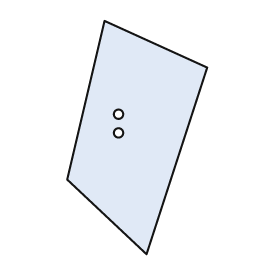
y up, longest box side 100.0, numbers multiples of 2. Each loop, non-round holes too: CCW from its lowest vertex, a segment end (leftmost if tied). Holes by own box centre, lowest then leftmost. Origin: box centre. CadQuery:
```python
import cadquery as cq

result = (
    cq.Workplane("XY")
    .moveTo(4.0, -50.0)
    .lineTo(30.0, 30.0)
    .lineTo(-14.0, 50.0)
    .lineTo(-30.0, -18.0)
    .close()
    .moveTo(-8.0, 2.0)
    .circle(2.0)
    .moveTo(-8.0, 10.0)
    .circle(2.0)
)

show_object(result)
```